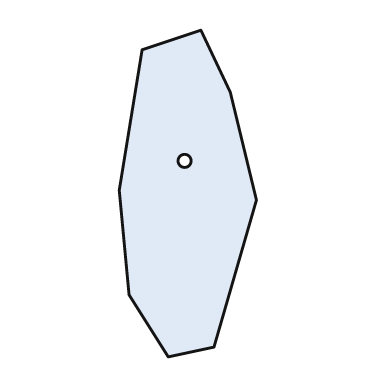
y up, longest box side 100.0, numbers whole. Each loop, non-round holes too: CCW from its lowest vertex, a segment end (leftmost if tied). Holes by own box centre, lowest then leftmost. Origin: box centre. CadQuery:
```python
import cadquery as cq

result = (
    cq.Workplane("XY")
    .moveTo(-6.0, -50.0)
    .lineTo(8.0, -47.0)
    .lineTo(21.0, -2.0)
    .lineTo(13.0, 31.0)
    .lineTo(4.0, 50.0)
    .lineTo(-14.0, 44.0)
    .lineTo(-21.0, 1.0)
    .lineTo(-18.0, -31.0)
    .close()
    .moveTo(-1.0, 10.0)
    .circle(2.0)
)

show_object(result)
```